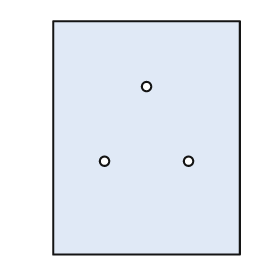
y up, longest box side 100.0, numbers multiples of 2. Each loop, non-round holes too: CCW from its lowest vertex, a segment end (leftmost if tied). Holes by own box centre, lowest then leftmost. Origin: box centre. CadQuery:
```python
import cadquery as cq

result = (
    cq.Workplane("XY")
    .moveTo(-40.0, -50.0)
    .lineTo(40.0, -50.0)
    .lineTo(40.0, 50.0)
    .lineTo(-40.0, 50.0)
    .close()
    .moveTo(-18.0, -10.0)
    .circle(2.0)
    .moveTo(18.0, -10.0)
    .circle(2.0)
    .moveTo(0.0, 22.0)
    .circle(2.0)
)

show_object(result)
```